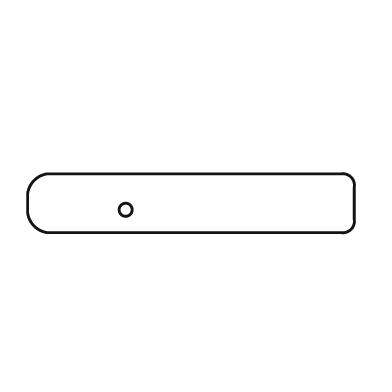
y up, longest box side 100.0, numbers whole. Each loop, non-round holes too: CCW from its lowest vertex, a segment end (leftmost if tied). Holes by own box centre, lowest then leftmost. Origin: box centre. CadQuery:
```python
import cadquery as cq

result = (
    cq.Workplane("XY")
    .moveTo(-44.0, -9.0)
    .lineTo(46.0, -9.0)
    .threePointArc((49.0, -8.0), (50.0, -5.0))
    .lineTo(50.0, 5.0)
    .threePointArc((49.0, 8.0), (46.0, 9.0))
    .lineTo(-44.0, 9.0)
    .threePointArc((-48.0, 7.0), (-50.0, 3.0))
    .lineTo(-50.0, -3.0)
    .threePointArc((-48.0, -7.0), (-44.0, -9.0))
    .close()
    .moveTo(-20.0, -2.0)
    .circle(2.0)
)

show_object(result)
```